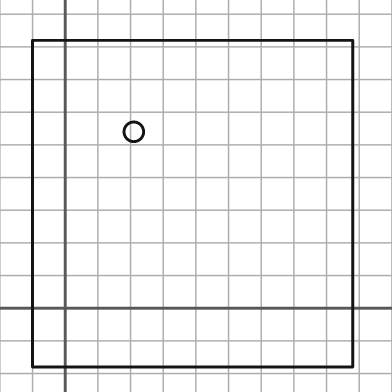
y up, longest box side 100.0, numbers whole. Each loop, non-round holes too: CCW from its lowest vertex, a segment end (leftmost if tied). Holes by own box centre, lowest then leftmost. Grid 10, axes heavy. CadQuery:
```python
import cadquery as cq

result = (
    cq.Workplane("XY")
    .moveTo(-10.0, -18.0)
    .lineTo(88.0, -18.0)
    .lineTo(88.0, 82.0)
    .lineTo(-10.0, 82.0)
    .close()
    .moveTo(21.0, 54.0)
    .circle(3.0)
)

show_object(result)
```